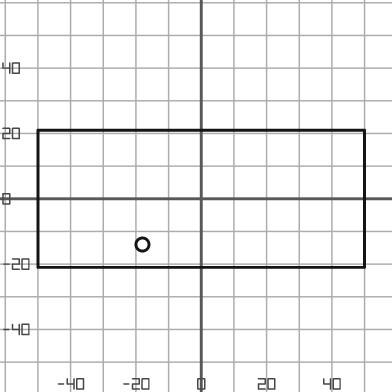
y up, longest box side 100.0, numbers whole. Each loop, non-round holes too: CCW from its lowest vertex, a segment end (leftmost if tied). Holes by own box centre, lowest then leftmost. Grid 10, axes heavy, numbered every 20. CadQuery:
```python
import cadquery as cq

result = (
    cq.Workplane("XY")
    .moveTo(-50.0, -21.0)
    .lineTo(50.0, -21.0)
    .lineTo(50.0, 21.0)
    .lineTo(-50.0, 21.0)
    .close()
    .moveTo(-18.0, -14.0)
    .circle(2.0)
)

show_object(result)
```